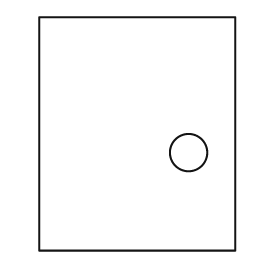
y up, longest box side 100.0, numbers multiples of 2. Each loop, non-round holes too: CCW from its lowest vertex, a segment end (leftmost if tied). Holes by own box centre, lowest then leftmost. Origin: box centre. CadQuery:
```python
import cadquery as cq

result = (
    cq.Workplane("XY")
    .moveTo(-42.0, -50.0)
    .lineTo(42.0, -50.0)
    .lineTo(42.0, 50.0)
    .lineTo(-42.0, 50.0)
    .close()
    .moveTo(22.0, -8.0)
    .circle(8.0)
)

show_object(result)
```